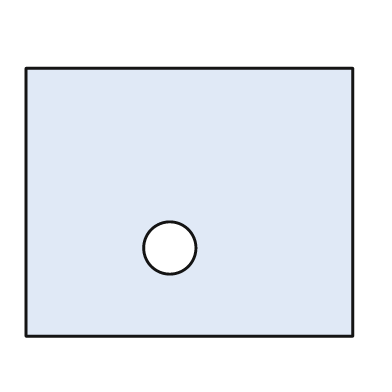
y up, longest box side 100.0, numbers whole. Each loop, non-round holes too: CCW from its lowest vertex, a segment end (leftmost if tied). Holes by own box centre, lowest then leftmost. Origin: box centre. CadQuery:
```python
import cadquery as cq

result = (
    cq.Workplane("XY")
    .moveTo(-50.0, -41.0)
    .lineTo(50.0, -41.0)
    .lineTo(50.0, 41.0)
    .lineTo(-50.0, 41.0)
    .close()
    .moveTo(-6.0, -14.0)
    .circle(8.0)
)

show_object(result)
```